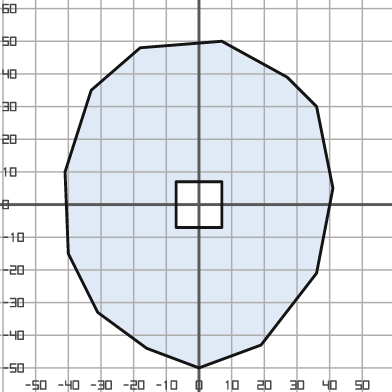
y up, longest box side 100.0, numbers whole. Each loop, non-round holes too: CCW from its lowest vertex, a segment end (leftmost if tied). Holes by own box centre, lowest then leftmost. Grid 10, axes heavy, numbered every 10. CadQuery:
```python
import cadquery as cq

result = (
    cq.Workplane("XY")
    .moveTo(0.0, -50.0)
    .lineTo(19.0, -43.0)
    .lineTo(36.0, -21.0)
    .lineTo(41.0, 5.0)
    .lineTo(36.0, 30.0)
    .lineTo(27.0, 39.0)
    .lineTo(7.0, 50.0)
    .lineTo(-18.0, 48.0)
    .lineTo(-33.0, 35.0)
    .lineTo(-41.0, 10.0)
    .lineTo(-40.0, -15.0)
    .lineTo(-31.0, -33.0)
    .lineTo(-16.0, -44.0)
    .close()
    .moveTo(-7.0, -7.0)
    .lineTo(7.0, -7.0)
    .lineTo(7.0, 7.0)
    .lineTo(-7.0, 7.0)
    .close()
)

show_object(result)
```